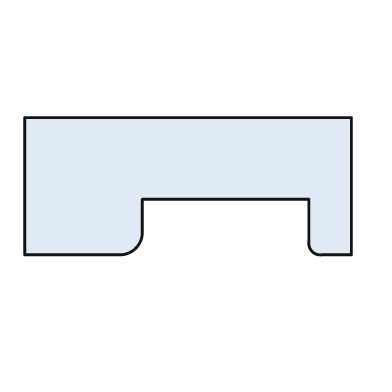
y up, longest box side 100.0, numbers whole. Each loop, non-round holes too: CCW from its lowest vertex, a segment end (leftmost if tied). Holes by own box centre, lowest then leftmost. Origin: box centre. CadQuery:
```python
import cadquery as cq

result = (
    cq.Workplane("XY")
    .moveTo(-50.0, -21.0)
    .lineTo(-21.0, -21.0)
    .threePointArc((-16.0, -19.0), (-14.0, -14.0))
    .lineTo(-14.0, -4.0)
    .lineTo(37.0, -4.0)
    .lineTo(37.0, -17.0)
    .threePointArc((38.0, -20.0), (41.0, -21.0))
    .lineTo(50.0, -21.0)
    .lineTo(50.0, 21.0)
    .lineTo(-50.0, 21.0)
    .close()
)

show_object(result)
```